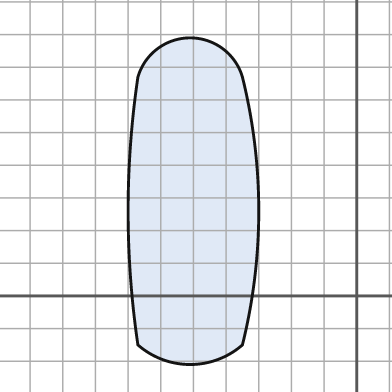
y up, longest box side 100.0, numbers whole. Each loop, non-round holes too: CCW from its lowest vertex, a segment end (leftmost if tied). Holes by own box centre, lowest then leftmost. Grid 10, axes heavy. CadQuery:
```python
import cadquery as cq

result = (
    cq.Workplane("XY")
    .moveTo(-67.0, -15.0)
    .threePointArc((-51.0, -21.0), (-35.0, -15.0))
    .threePointArc((-30.0, 26.0), (-35.0, 67.0))
    .threePointArc((-51.0, 79.0), (-67.0, 67.0))
    .threePointArc((-70.0, 26.0), (-67.0, -15.0))
    .close()
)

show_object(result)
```